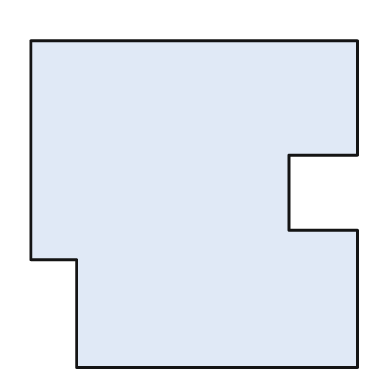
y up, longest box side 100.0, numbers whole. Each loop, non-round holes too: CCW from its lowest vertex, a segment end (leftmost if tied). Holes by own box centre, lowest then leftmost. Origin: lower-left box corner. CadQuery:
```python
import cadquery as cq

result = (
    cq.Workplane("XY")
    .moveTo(14.0, 0.0)
    .lineTo(100.0, 0.0)
    .lineTo(100.0, 42.0)
    .lineTo(79.0, 42.0)
    .lineTo(79.0, 65.0)
    .lineTo(100.0, 65.0)
    .lineTo(100.0, 100.0)
    .lineTo(0.0, 100.0)
    .lineTo(0.0, 33.0)
    .lineTo(14.0, 33.0)
    .close()
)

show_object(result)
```